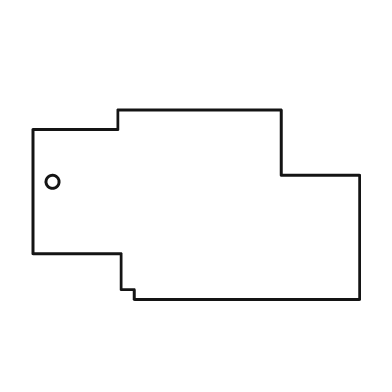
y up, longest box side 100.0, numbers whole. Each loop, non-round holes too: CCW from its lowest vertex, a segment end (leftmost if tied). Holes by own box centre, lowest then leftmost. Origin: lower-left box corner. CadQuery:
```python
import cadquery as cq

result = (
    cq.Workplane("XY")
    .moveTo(31.0, 0.0)
    .lineTo(100.0, 0.0)
    .lineTo(100.0, 38.0)
    .lineTo(76.0, 38.0)
    .lineTo(76.0, 58.0)
    .lineTo(26.0, 58.0)
    .lineTo(26.0, 52.0)
    .lineTo(0.0, 52.0)
    .lineTo(0.0, 14.0)
    .lineTo(27.0, 14.0)
    .lineTo(27.0, 3.0)
    .lineTo(31.0, 3.0)
    .close()
    .moveTo(6.0, 36.0)
    .circle(2.0)
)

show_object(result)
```